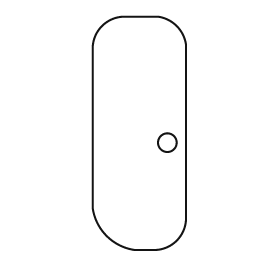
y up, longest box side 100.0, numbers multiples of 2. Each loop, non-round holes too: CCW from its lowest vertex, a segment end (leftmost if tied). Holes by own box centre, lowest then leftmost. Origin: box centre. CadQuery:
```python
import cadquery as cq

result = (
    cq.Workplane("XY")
    .moveTo(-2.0, -50.0)
    .lineTo(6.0, -50.0)
    .threePointArc((16.0, -46.0), (20.0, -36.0))
    .lineTo(20.0, 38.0)
    .threePointArc((16.0, 46.0), (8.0, 50.0))
    .lineTo(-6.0, 50.0)
    .threePointArc((-16.0, 46.0), (-20.0, 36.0))
    .lineTo(-20.0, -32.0)
    .threePointArc((-14.0, -44.0), (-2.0, -50.0))
    .close()
    .moveTo(12.0, -4.0)
    .circle(4.0)
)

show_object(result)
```